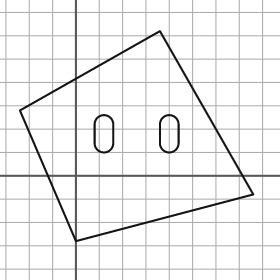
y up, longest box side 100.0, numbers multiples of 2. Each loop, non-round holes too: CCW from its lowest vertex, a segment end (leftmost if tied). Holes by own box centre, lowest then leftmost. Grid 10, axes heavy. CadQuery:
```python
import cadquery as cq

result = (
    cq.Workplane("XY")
    .moveTo(0.0, -28.0)
    .lineTo(76.0, -8.0)
    .lineTo(36.0, 62.0)
    .lineTo(-24.0, 28.0)
    .close()
    .moveTo(8.0, 14.0)
    .threePointArc((12.0, 10.0), (16.0, 14.0))
    .lineTo(16.0, 22.0)
    .threePointArc((12.0, 26.0), (8.0, 22.0))
    .close()
    .moveTo(36.0, 14.0)
    .threePointArc((40.0, 10.0), (44.0, 14.0))
    .lineTo(44.0, 22.0)
    .threePointArc((40.0, 26.0), (36.0, 22.0))
    .close()
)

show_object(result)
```